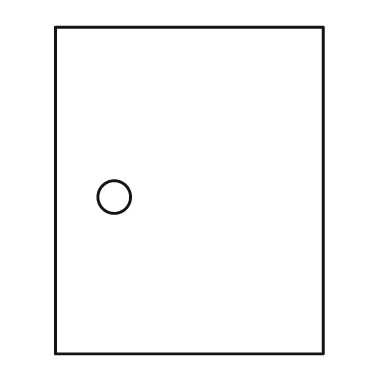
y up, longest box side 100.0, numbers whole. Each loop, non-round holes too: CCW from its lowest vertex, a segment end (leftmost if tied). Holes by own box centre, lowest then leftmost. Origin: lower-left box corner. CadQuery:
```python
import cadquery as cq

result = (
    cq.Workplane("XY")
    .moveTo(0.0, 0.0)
    .lineTo(82.0, 0.0)
    .lineTo(82.0, 100.0)
    .lineTo(0.0, 100.0)
    .close()
    .moveTo(18.0, 48.0)
    .circle(5.0)
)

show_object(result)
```